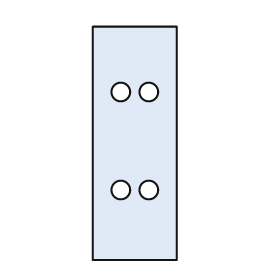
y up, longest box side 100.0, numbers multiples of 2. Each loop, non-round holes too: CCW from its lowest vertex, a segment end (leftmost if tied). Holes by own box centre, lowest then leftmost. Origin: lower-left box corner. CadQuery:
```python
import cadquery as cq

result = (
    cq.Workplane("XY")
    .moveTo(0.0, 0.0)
    .lineTo(36.0, 0.0)
    .lineTo(36.0, 100.0)
    .lineTo(0.0, 100.0)
    .close()
    .moveTo(12.0, 30.0)
    .circle(4.0)
    .moveTo(24.0, 30.0)
    .circle(4.0)
    .moveTo(12.0, 72.0)
    .circle(4.0)
    .moveTo(24.0, 72.0)
    .circle(4.0)
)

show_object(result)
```